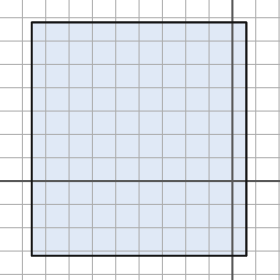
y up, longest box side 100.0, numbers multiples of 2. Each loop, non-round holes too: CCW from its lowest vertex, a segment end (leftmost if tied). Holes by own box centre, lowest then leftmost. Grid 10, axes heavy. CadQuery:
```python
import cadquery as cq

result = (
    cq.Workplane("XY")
    .moveTo(-86.0, -32.0)
    .lineTo(6.0, -32.0)
    .lineTo(6.0, 68.0)
    .lineTo(-86.0, 68.0)
    .close()
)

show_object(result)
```